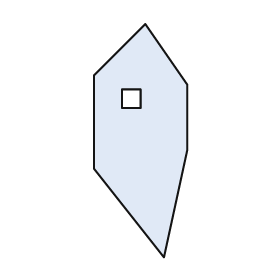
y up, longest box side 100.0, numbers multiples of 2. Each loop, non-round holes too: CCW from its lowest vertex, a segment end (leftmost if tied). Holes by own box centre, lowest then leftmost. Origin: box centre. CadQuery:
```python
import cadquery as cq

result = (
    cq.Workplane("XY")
    .moveTo(10.0, -50.0)
    .lineTo(20.0, -4.0)
    .lineTo(20.0, 24.0)
    .lineTo(2.0, 50.0)
    .lineTo(-20.0, 28.0)
    .lineTo(-20.0, -12.0)
    .close()
    .moveTo(-8.0, 14.0)
    .lineTo(0.0, 14.0)
    .lineTo(0.0, 22.0)
    .lineTo(-8.0, 22.0)
    .close()
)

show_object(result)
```